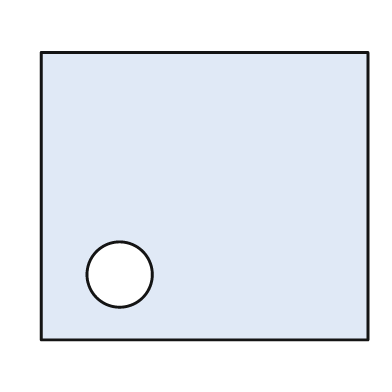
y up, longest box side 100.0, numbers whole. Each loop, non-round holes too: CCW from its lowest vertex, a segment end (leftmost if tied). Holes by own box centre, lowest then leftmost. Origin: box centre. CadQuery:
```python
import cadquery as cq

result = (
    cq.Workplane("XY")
    .moveTo(-50.0, -44.0)
    .lineTo(50.0, -44.0)
    .lineTo(50.0, 44.0)
    .lineTo(-50.0, 44.0)
    .close()
    .moveTo(-26.0, -24.0)
    .circle(10.0)
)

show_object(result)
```